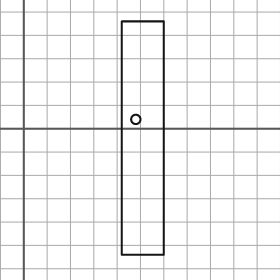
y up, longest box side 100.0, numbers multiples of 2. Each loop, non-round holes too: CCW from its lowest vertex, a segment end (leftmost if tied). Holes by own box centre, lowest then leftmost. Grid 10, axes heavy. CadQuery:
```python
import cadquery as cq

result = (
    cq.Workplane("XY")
    .moveTo(42.0, -54.0)
    .lineTo(60.0, -54.0)
    .lineTo(60.0, 46.0)
    .lineTo(42.0, 46.0)
    .close()
    .moveTo(48.0, 4.0)
    .circle(2.0)
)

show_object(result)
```